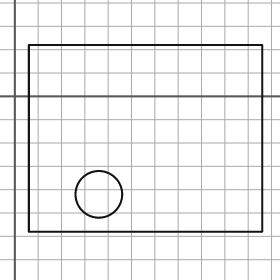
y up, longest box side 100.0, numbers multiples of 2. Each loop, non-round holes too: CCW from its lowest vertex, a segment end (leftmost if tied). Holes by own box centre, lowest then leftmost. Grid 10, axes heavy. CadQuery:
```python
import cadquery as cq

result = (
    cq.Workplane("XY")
    .moveTo(6.0, -58.0)
    .lineTo(106.0, -58.0)
    .lineTo(106.0, 22.0)
    .lineTo(6.0, 22.0)
    .close()
    .moveTo(36.0, -42.0)
    .circle(10.0)
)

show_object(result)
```